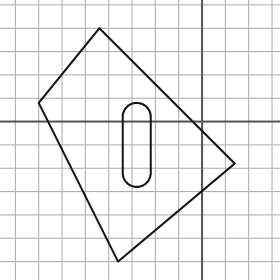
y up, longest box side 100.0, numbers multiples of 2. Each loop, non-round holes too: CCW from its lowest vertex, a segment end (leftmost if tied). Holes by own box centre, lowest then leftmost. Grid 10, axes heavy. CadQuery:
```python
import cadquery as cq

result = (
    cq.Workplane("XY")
    .moveTo(-36.0, -60.0)
    .lineTo(14.0, -18.0)
    .lineTo(-44.0, 40.0)
    .lineTo(-70.0, 8.0)
    .close()
    .moveTo(-34.0, -22.0)
    .threePointArc((-28.0, -28.0), (-22.0, -22.0))
    .lineTo(-22.0, 2.0)
    .threePointArc((-28.0, 8.0), (-34.0, 2.0))
    .close()
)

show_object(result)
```